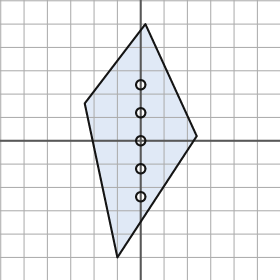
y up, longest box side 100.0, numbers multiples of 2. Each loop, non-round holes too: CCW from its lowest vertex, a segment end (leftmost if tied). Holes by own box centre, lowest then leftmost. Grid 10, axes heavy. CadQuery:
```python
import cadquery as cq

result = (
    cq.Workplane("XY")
    .moveTo(-10.0, -50.0)
    .lineTo(24.0, 2.0)
    .lineTo(2.0, 50.0)
    .lineTo(-24.0, 16.0)
    .close()
    .moveTo(0.0, -24.0)
    .circle(2.0)
    .moveTo(0.0, -12.0)
    .circle(2.0)
    .moveTo(0.0, 0.0)
    .circle(2.0)
    .moveTo(0.0, 12.0)
    .circle(2.0)
    .moveTo(0.0, 24.0)
    .circle(2.0)
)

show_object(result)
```